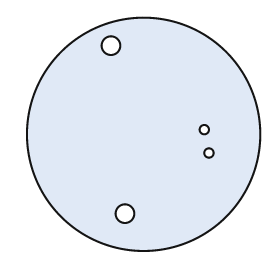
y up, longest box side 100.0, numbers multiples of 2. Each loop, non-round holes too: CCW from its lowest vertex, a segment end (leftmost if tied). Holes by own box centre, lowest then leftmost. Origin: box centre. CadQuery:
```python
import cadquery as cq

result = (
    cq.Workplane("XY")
    .moveTo(0.0, 0.0)
    .circle(50.0)
    .moveTo(-8.0, -34.0)
    .circle(4.0)
    .moveTo(28.0, -8.0)
    .circle(2.0)
    .moveTo(26.0, 2.0)
    .circle(2.0)
    .moveTo(-14.0, 38.0)
    .circle(4.0)
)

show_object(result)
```